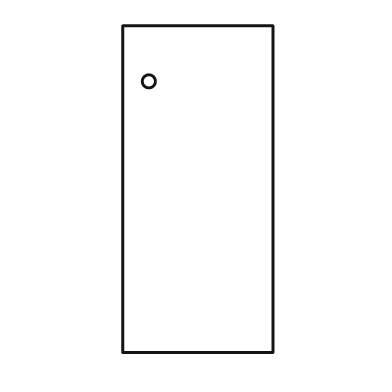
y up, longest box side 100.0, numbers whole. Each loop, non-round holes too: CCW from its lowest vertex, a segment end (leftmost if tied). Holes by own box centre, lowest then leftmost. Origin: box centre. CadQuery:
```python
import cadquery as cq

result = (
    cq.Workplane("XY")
    .moveTo(-23.0, -50.0)
    .lineTo(23.0, -50.0)
    .lineTo(23.0, 50.0)
    .lineTo(-23.0, 50.0)
    .close()
    .moveTo(-15.0, 33.0)
    .circle(2.0)
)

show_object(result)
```